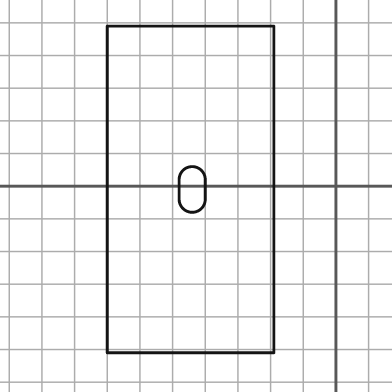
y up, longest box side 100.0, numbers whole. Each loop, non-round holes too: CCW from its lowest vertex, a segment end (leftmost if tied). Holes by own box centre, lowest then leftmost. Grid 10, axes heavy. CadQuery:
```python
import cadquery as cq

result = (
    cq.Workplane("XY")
    .moveTo(-70.0, -51.0)
    .lineTo(-19.0, -51.0)
    .lineTo(-19.0, 49.0)
    .lineTo(-70.0, 49.0)
    .close()
    .moveTo(-48.0, -4.0)
    .threePointArc((-44.0, -8.0), (-40.0, -4.0))
    .lineTo(-40.0, 2.0)
    .threePointArc((-44.0, 6.0), (-48.0, 2.0))
    .close()
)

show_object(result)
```